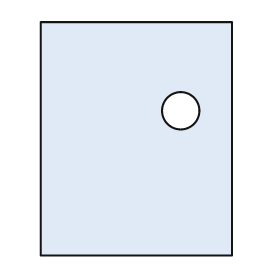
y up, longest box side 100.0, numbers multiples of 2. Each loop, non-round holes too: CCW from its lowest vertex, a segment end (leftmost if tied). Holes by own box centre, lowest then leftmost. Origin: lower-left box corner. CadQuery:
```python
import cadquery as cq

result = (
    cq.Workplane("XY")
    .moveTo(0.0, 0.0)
    .lineTo(82.0, 0.0)
    .lineTo(82.0, 100.0)
    .lineTo(0.0, 100.0)
    .close()
    .moveTo(60.0, 62.0)
    .circle(8.0)
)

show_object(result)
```